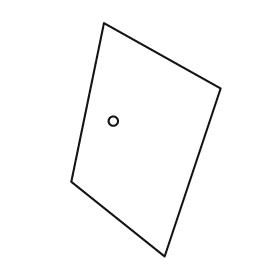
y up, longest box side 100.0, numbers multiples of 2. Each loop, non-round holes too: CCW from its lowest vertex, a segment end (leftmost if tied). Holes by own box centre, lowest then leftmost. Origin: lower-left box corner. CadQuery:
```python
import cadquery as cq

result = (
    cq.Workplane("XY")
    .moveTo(40.0, 0.0)
    .lineTo(64.0, 72.0)
    .lineTo(14.0, 100.0)
    .lineTo(0.0, 32.0)
    .close()
    .moveTo(18.0, 58.0)
    .circle(2.0)
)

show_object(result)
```